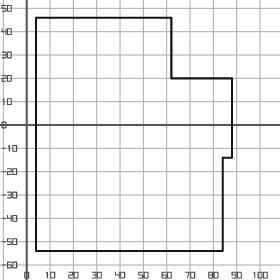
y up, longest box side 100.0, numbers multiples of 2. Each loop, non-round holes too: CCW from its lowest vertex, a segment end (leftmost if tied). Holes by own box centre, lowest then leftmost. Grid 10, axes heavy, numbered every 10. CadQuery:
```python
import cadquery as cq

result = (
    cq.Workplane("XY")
    .moveTo(4.0, -54.0)
    .lineTo(84.0, -54.0)
    .lineTo(84.0, -14.0)
    .lineTo(88.0, -14.0)
    .lineTo(88.0, 20.0)
    .lineTo(62.0, 20.0)
    .lineTo(62.0, 46.0)
    .lineTo(4.0, 46.0)
    .close()
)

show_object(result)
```